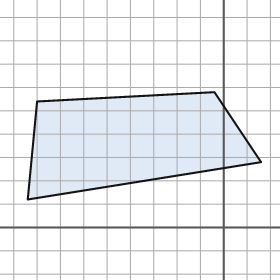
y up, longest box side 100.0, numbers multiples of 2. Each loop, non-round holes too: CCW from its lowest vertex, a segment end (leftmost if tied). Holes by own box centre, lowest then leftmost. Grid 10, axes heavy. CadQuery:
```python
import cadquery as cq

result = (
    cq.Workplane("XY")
    .moveTo(-84.0, 12.0)
    .lineTo(16.0, 28.0)
    .lineTo(-4.0, 58.0)
    .lineTo(-80.0, 54.0)
    .close()
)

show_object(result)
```